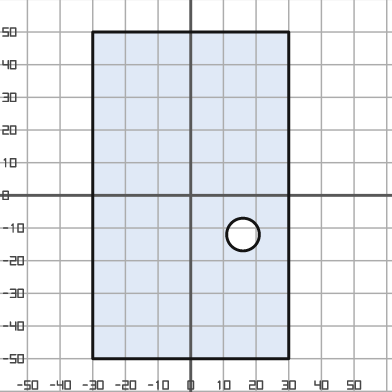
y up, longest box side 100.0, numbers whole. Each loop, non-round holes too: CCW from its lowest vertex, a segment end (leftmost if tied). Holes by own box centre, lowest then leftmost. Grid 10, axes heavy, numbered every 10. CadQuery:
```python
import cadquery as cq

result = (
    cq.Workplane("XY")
    .moveTo(-30.0, -50.0)
    .lineTo(30.0, -50.0)
    .lineTo(30.0, 50.0)
    .lineTo(-30.0, 50.0)
    .close()
    .moveTo(16.0, -12.0)
    .circle(5.0)
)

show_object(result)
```